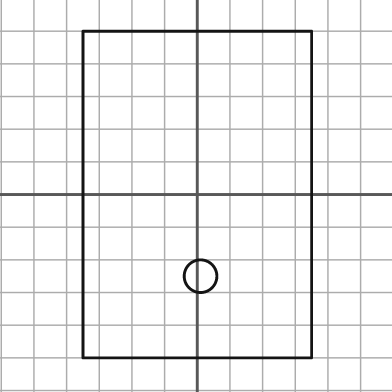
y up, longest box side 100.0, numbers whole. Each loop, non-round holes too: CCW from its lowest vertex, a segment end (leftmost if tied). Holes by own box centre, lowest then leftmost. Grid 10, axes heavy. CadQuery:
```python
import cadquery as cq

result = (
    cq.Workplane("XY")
    .moveTo(-35.0, -50.0)
    .lineTo(35.0, -50.0)
    .lineTo(35.0, 50.0)
    .lineTo(-35.0, 50.0)
    .close()
    .moveTo(1.0, -25.0)
    .circle(5.0)
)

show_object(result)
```